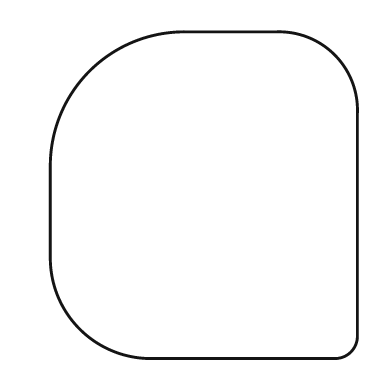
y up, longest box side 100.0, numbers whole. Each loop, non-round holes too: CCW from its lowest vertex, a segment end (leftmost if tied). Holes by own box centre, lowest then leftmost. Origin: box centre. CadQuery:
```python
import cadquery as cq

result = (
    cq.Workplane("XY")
    .moveTo(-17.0, -50.0)
    .lineTo(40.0, -50.0)
    .threePointArc((45.0, -48.0), (47.0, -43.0))
    .lineTo(47.0, 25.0)
    .threePointArc((40.0, 43.0), (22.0, 50.0))
    .lineTo(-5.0, 50.0)
    .threePointArc((-35.0, 38.0), (-47.0, 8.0))
    .lineTo(-47.0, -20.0)
    .threePointArc((-38.0, -41.0), (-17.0, -50.0))
    .close()
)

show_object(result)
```